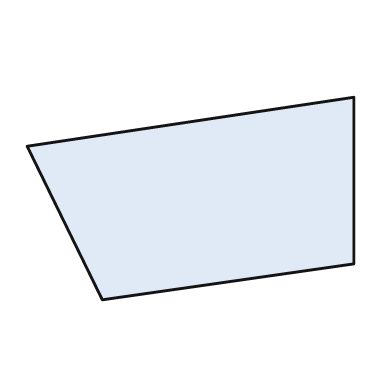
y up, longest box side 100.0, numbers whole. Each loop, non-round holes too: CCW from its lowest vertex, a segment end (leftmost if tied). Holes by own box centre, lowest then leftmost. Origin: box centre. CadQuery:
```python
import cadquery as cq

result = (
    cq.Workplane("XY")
    .moveTo(-27.0, -31.0)
    .lineTo(50.0, -20.0)
    .lineTo(50.0, 31.0)
    .lineTo(-50.0, 16.0)
    .close()
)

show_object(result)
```